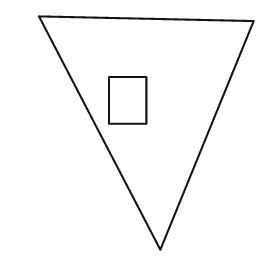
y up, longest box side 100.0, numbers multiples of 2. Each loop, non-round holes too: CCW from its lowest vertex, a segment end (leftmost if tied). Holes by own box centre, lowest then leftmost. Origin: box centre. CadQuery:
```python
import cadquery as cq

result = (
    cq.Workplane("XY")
    .moveTo(6.0, -50.0)
    .lineTo(46.0, 48.0)
    .lineTo(-46.0, 50.0)
    .close()
    .moveTo(-16.0, 4.0)
    .lineTo(0.0, 4.0)
    .lineTo(0.0, 24.0)
    .lineTo(-16.0, 24.0)
    .close()
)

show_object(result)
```